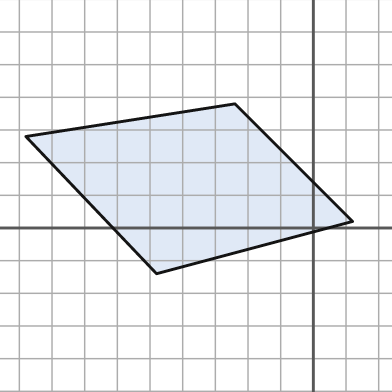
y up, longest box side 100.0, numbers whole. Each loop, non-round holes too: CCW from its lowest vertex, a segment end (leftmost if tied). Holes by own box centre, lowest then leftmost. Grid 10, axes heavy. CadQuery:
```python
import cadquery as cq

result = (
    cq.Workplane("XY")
    .moveTo(-48.0, -14.0)
    .lineTo(12.0, 2.0)
    .lineTo(-24.0, 38.0)
    .lineTo(-88.0, 28.0)
    .close()
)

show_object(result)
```